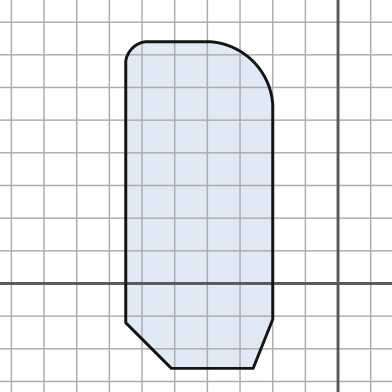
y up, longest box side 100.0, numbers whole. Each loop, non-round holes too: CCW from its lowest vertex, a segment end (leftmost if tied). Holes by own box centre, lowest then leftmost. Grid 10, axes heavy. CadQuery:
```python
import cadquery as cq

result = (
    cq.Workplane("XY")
    .moveTo(-51.0, -26.0)
    .lineTo(-26.0, -26.0)
    .lineTo(-20.0, -11.0)
    .lineTo(-20.0, 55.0)
    .threePointArc((-26.0, 68.0), (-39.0, 74.0))
    .lineTo(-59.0, 74.0)
    .threePointArc((-63.0, 72.0), (-65.0, 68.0))
    .lineTo(-65.0, -12.0)
    .close()
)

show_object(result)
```